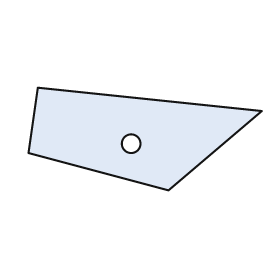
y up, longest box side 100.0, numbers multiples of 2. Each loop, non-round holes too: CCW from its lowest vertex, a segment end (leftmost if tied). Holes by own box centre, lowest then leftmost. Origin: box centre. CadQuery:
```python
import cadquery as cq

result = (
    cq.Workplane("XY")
    .moveTo(10.0, -22.0)
    .lineTo(50.0, 12.0)
    .lineTo(-46.0, 22.0)
    .lineTo(-50.0, -6.0)
    .close()
    .moveTo(-6.0, -2.0)
    .circle(4.0)
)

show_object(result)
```